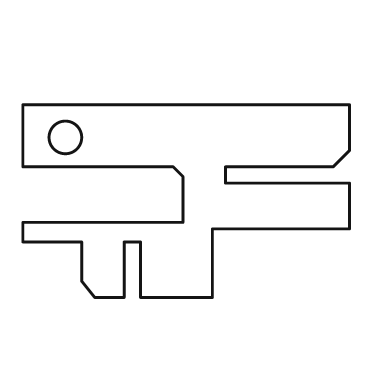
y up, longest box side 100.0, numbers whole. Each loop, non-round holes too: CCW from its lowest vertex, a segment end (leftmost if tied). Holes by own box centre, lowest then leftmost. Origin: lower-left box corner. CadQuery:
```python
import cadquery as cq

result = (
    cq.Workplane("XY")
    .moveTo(22.0, 0.0)
    .lineTo(31.0, 0.0)
    .lineTo(31.0, 17.0)
    .lineTo(36.0, 17.0)
    .lineTo(36.0, 0.0)
    .lineTo(58.0, 0.0)
    .lineTo(58.0, 21.0)
    .lineTo(100.0, 21.0)
    .lineTo(100.0, 35.0)
    .lineTo(62.0, 35.0)
    .lineTo(62.0, 40.0)
    .lineTo(95.0, 40.0)
    .lineTo(100.0, 45.0)
    .lineTo(100.0, 59.0)
    .lineTo(0.0, 59.0)
    .lineTo(0.0, 40.0)
    .lineTo(46.0, 40.0)
    .lineTo(49.0, 37.0)
    .lineTo(49.0, 23.0)
    .lineTo(0.0, 23.0)
    .lineTo(0.0, 17.0)
    .lineTo(18.0, 17.0)
    .lineTo(18.0, 5.0)
    .close()
    .moveTo(13.0, 49.0)
    .circle(5.0)
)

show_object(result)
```